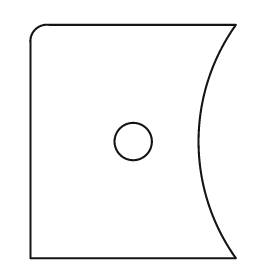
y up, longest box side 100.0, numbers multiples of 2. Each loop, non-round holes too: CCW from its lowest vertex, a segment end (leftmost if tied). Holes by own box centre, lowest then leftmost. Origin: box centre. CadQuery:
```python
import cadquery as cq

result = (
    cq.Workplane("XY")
    .moveTo(-44.0, -50.0)
    .lineTo(44.0, -50.0)
    .threePointArc((28.0, 0.0), (44.0, 50.0))
    .lineTo(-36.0, 50.0)
    .threePointArc((-42.0, 48.0), (-44.0, 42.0))
    .close()
    .moveTo(0.0, 0.0)
    .circle(8.0)
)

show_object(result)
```